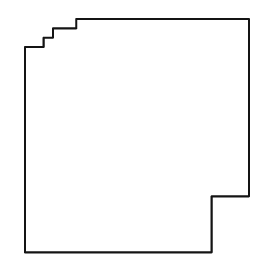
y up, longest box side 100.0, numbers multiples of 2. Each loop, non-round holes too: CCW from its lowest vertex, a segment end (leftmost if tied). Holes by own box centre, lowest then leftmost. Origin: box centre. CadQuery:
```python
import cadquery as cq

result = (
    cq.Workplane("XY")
    .moveTo(-48.0, -50.0)
    .lineTo(32.0, -50.0)
    .lineTo(32.0, -26.0)
    .lineTo(48.0, -26.0)
    .lineTo(48.0, 50.0)
    .lineTo(-26.0, 50.0)
    .lineTo(-26.0, 46.0)
    .lineTo(-36.0, 46.0)
    .lineTo(-36.0, 42.0)
    .lineTo(-40.0, 42.0)
    .lineTo(-40.0, 38.0)
    .lineTo(-48.0, 38.0)
    .close()
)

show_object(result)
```